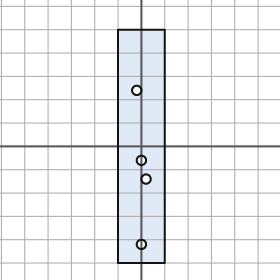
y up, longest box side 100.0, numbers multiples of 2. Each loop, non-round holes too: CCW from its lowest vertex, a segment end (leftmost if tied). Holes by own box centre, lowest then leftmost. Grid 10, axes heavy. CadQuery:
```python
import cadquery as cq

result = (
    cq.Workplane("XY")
    .moveTo(-10.0, -50.0)
    .lineTo(10.0, -50.0)
    .lineTo(10.0, 50.0)
    .lineTo(-10.0, 50.0)
    .close()
    .moveTo(0.0, -42.0)
    .circle(2.0)
    .moveTo(2.0, -14.0)
    .circle(2.0)
    .moveTo(0.0, -6.0)
    .circle(2.0)
    .moveTo(-2.0, 24.0)
    .circle(2.0)
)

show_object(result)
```